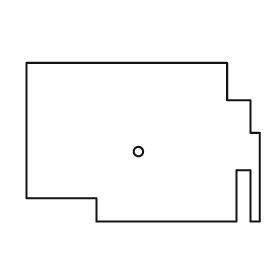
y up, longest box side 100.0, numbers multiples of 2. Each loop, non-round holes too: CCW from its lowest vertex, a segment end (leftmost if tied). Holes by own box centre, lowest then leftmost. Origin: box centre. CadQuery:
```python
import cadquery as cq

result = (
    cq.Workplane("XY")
    .moveTo(-20.0, -34.0)
    .lineTo(40.0, -34.0)
    .lineTo(40.0, -12.0)
    .lineTo(46.0, -12.0)
    .lineTo(46.0, -34.0)
    .lineTo(50.0, -34.0)
    .lineTo(50.0, 4.0)
    .lineTo(46.0, 4.0)
    .lineTo(46.0, 18.0)
    .lineTo(36.0, 18.0)
    .lineTo(36.0, 34.0)
    .lineTo(-50.0, 34.0)
    .lineTo(-50.0, -24.0)
    .lineTo(-20.0, -24.0)
    .close()
    .moveTo(-2.0, -4.0)
    .circle(2.0)
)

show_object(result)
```